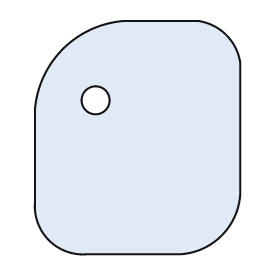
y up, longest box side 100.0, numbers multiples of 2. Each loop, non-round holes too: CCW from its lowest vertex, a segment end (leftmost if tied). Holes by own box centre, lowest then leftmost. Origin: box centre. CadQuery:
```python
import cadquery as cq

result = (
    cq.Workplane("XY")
    .moveTo(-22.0, -50.0)
    .lineTo(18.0, -50.0)
    .threePointArc((36.0, -42.0), (44.0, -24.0))
    .lineTo(44.0, 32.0)
    .threePointArc((38.0, 44.0), (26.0, 50.0))
    .lineTo(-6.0, 50.0)
    .threePointArc((-32.0, 38.0), (-44.0, 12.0))
    .lineTo(-44.0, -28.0)
    .threePointArc((-38.0, -44.0), (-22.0, -50.0))
    .close()
    .moveTo(-18.0, 16.0)
    .circle(6.0)
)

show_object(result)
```